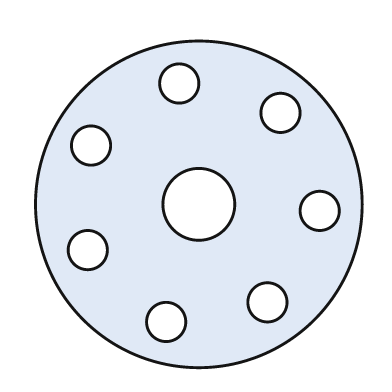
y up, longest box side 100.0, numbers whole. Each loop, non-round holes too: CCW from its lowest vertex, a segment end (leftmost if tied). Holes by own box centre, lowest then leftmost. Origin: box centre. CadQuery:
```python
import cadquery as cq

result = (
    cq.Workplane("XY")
    .moveTo(0.0, 0.0)
    .circle(50.0)
    .moveTo(-10.0, -36.0)
    .circle(6.0)
    .moveTo(21.0, -30.0)
    .circle(6.0)
    .moveTo(-34.0, -14.0)
    .circle(6.0)
    .moveTo(37.0, -2.0)
    .circle(6.0)
    .moveTo(0.0, 0.0)
    .circle(11.0)
    .moveTo(-33.0, 18.0)
    .circle(6.0)
    .moveTo(25.0, 28.0)
    .circle(6.0)
    .moveTo(-6.0, 37.0)
    .circle(6.0)
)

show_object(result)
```